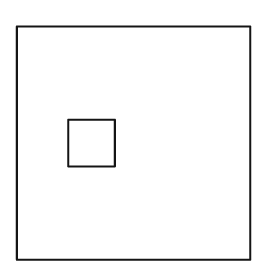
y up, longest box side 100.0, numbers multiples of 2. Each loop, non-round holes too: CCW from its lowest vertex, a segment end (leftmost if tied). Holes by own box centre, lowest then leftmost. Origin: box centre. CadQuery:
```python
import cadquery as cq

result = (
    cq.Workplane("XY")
    .moveTo(-50.0, -50.0)
    .lineTo(50.0, -50.0)
    .lineTo(50.0, 50.0)
    .lineTo(-50.0, 50.0)
    .close()
    .moveTo(-28.0, -10.0)
    .lineTo(-8.0, -10.0)
    .lineTo(-8.0, 10.0)
    .lineTo(-28.0, 10.0)
    .close()
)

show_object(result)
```